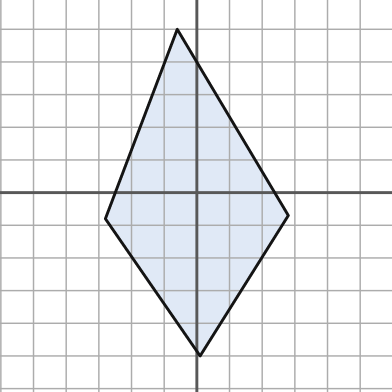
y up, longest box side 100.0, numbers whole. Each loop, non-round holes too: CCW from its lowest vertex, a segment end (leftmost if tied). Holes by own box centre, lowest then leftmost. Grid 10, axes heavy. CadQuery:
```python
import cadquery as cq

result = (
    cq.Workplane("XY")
    .moveTo(1.0, -50.0)
    .lineTo(28.0, -7.0)
    .lineTo(-6.0, 50.0)
    .lineTo(-28.0, -8.0)
    .close()
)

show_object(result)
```